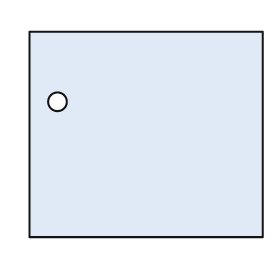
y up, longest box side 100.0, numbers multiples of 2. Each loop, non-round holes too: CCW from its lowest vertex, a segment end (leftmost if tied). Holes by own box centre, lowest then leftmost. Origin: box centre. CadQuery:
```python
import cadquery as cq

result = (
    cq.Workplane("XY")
    .moveTo(-50.0, -44.0)
    .lineTo(50.0, -44.0)
    .lineTo(50.0, 44.0)
    .lineTo(-50.0, 44.0)
    .close()
    .moveTo(-38.0, 14.0)
    .circle(4.0)
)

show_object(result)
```